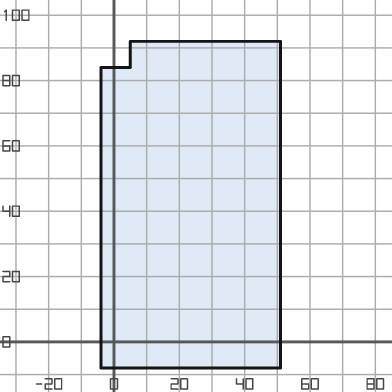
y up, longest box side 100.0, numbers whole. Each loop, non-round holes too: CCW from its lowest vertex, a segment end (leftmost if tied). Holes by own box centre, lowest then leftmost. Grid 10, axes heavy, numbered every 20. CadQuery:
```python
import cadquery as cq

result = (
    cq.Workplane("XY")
    .moveTo(-4.0, -8.0)
    .lineTo(51.0, -8.0)
    .lineTo(51.0, 92.0)
    .lineTo(5.0, 92.0)
    .lineTo(5.0, 84.0)
    .lineTo(-4.0, 84.0)
    .close()
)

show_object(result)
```